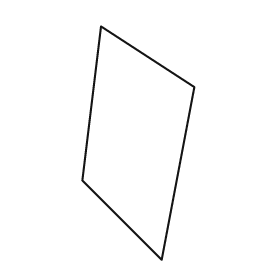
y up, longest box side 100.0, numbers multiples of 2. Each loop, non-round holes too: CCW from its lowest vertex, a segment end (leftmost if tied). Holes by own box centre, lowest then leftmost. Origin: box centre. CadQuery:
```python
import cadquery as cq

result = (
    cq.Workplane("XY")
    .moveTo(10.0, -50.0)
    .lineTo(24.0, 24.0)
    .lineTo(-16.0, 50.0)
    .lineTo(-24.0, -16.0)
    .close()
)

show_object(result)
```